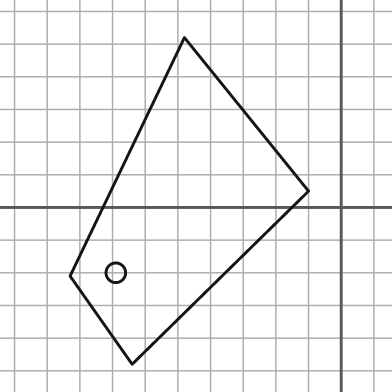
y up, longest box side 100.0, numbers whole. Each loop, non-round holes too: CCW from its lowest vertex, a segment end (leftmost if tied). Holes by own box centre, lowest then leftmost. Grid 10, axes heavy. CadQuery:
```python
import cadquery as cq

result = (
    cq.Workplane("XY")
    .moveTo(-64.0, -48.0)
    .lineTo(-10.0, 5.0)
    .lineTo(-48.0, 52.0)
    .lineTo(-83.0, -21.0)
    .close()
    .moveTo(-69.0, -20.0)
    .circle(3.0)
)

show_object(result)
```